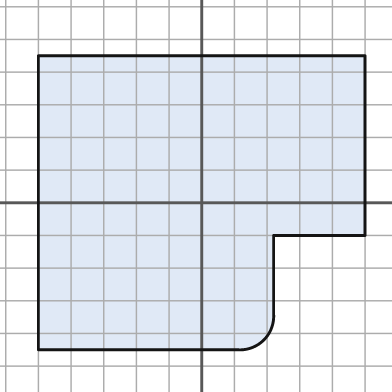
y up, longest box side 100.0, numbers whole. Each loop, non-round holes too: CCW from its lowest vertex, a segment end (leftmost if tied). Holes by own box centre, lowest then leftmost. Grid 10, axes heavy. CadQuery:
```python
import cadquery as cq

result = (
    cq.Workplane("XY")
    .moveTo(-50.0, -45.0)
    .lineTo(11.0, -45.0)
    .threePointArc((19.0, -42.0), (22.0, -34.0))
    .lineTo(22.0, -10.0)
    .lineTo(50.0, -10.0)
    .lineTo(50.0, 45.0)
    .lineTo(-50.0, 45.0)
    .close()
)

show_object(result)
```